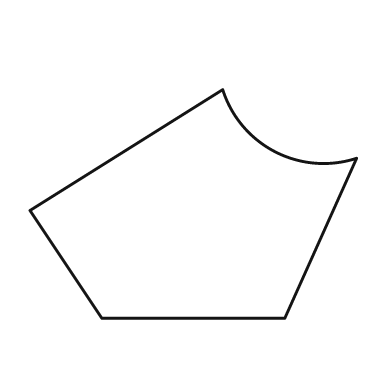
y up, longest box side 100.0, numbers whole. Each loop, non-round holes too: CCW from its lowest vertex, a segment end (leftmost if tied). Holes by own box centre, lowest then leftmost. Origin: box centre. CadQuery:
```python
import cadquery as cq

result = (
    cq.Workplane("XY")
    .moveTo(-28.0, -35.0)
    .lineTo(28.0, -35.0)
    .lineTo(50.0, 14.0)
    .threePointArc((25.0, 16.0), (9.0, 35.0))
    .lineTo(-50.0, -2.0)
    .close()
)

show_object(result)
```